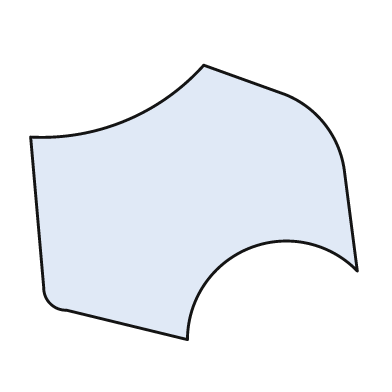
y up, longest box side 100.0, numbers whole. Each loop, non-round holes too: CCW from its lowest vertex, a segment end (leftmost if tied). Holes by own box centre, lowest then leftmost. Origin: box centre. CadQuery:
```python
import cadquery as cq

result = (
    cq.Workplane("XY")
    .moveTo(-2.0, -42.0)
    .threePointArc((17.0, -14.0), (50.0, -21.0))
    .lineTo(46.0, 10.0)
    .threePointArc((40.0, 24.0), (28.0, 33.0))
    .lineTo(3.0, 42.0)
    .threePointArc((-21.0, 25.0), (-50.0, 20.0))
    .lineTo(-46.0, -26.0)
    .threePointArc((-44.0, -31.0), (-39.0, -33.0))
    .close()
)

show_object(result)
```